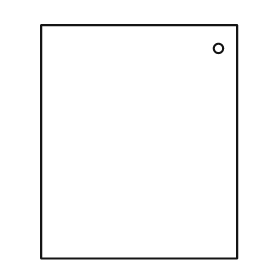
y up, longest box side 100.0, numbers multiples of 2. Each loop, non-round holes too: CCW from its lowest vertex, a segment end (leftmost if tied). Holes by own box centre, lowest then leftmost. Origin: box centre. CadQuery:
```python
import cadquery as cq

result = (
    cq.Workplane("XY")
    .moveTo(-42.0, -50.0)
    .lineTo(42.0, -50.0)
    .lineTo(42.0, 50.0)
    .lineTo(-42.0, 50.0)
    .close()
    .moveTo(34.0, 40.0)
    .circle(2.0)
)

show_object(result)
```